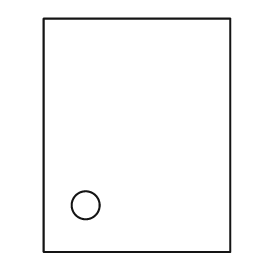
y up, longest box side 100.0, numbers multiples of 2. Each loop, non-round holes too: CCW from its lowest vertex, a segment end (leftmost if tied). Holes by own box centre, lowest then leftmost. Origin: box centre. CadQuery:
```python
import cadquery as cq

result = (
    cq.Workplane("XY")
    .moveTo(-40.0, -50.0)
    .lineTo(40.0, -50.0)
    .lineTo(40.0, 50.0)
    .lineTo(-40.0, 50.0)
    .close()
    .moveTo(-22.0, -30.0)
    .circle(6.0)
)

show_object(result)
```